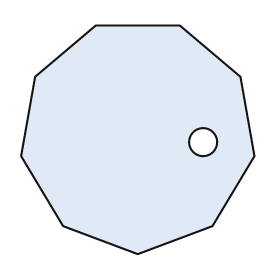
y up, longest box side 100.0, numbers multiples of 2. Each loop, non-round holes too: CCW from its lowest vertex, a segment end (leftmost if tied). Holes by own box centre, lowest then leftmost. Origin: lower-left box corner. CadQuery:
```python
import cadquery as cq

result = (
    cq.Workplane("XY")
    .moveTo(50.0, 0.0)
    .lineTo(82.0, 12.0)
    .lineTo(100.0, 42.0)
    .lineTo(94.0, 76.0)
    .lineTo(68.0, 98.0)
    .lineTo(32.0, 98.0)
    .lineTo(6.0, 76.0)
    .lineTo(0.0, 42.0)
    .lineTo(18.0, 12.0)
    .close()
    .moveTo(78.0, 48.0)
    .circle(6.0)
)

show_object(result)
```